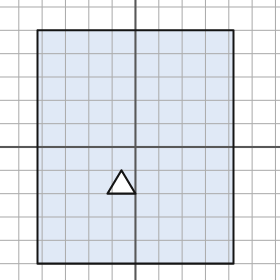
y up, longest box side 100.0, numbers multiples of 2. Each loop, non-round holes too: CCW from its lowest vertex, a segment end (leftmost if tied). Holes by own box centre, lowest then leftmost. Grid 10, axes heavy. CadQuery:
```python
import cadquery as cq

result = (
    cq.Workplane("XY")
    .moveTo(-42.0, -50.0)
    .lineTo(42.0, -50.0)
    .lineTo(42.0, 50.0)
    .lineTo(-42.0, 50.0)
    .close()
    .moveTo(-12.0, -20.0)
    .lineTo(0.0, -20.0)
    .lineTo(-6.0, -10.0)
    .close()
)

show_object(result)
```